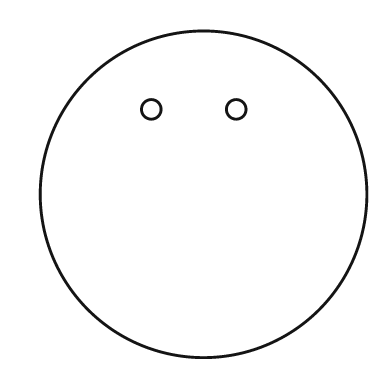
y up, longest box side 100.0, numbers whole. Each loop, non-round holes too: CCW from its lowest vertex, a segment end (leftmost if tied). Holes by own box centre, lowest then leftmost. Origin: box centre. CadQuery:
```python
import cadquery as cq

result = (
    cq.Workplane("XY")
    .moveTo(0.0, 0.0)
    .circle(50.0)
    .moveTo(-16.0, 26.0)
    .circle(3.0)
    .moveTo(10.0, 26.0)
    .circle(3.0)
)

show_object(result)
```